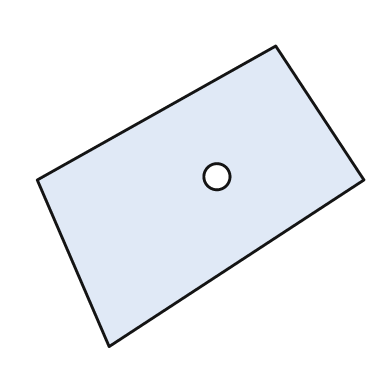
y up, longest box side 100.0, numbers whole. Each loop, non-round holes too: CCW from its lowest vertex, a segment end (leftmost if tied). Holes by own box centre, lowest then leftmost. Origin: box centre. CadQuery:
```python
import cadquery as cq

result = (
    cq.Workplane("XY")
    .moveTo(-28.0, -46.0)
    .lineTo(50.0, 5.0)
    .lineTo(23.0, 46.0)
    .lineTo(-50.0, 5.0)
    .close()
    .moveTo(5.0, 6.0)
    .circle(4.0)
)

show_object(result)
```